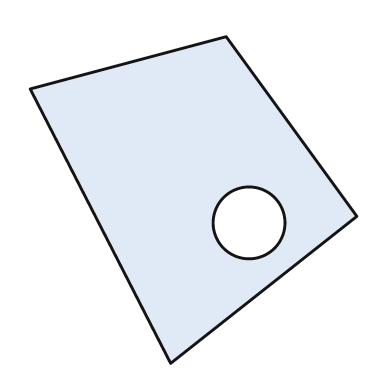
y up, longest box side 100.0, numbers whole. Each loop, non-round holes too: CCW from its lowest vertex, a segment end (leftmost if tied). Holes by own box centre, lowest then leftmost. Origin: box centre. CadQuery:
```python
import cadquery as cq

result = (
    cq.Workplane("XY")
    .moveTo(-7.0, -50.0)
    .lineTo(50.0, -5.0)
    .lineTo(10.0, 50.0)
    .lineTo(-50.0, 34.0)
    .close()
    .moveTo(17.0, -7.0)
    .circle(11.0)
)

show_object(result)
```